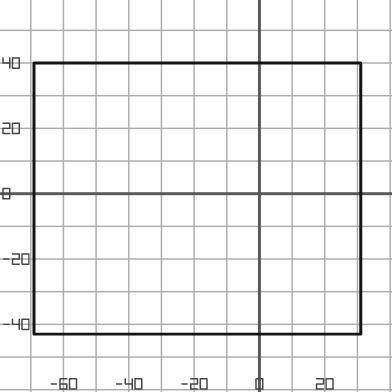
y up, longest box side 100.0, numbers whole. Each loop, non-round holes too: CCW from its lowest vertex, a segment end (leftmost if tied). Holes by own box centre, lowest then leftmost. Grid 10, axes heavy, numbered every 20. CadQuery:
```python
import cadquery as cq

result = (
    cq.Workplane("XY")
    .moveTo(-69.0, -43.0)
    .lineTo(31.0, -43.0)
    .lineTo(31.0, 40.0)
    .lineTo(-69.0, 40.0)
    .close()
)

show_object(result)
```